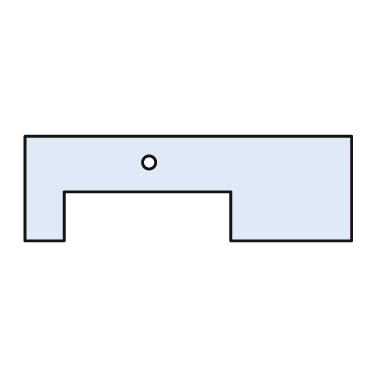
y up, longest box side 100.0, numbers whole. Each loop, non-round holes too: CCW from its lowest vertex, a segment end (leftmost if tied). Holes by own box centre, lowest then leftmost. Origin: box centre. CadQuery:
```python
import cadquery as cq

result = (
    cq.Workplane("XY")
    .moveTo(-50.0, -16.0)
    .lineTo(-38.0, -16.0)
    .lineTo(-38.0, -1.0)
    .lineTo(13.0, -1.0)
    .lineTo(13.0, -16.0)
    .lineTo(50.0, -16.0)
    .lineTo(50.0, 16.0)
    .lineTo(-50.0, 16.0)
    .close()
    .moveTo(-12.0, 8.0)
    .circle(2.0)
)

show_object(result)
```